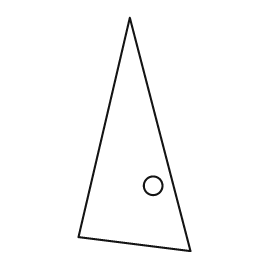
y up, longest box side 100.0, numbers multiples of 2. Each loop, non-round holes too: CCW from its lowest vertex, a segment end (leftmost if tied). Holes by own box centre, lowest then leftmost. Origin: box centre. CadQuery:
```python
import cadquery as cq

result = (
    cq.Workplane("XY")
    .moveTo(24.0, -50.0)
    .lineTo(-2.0, 50.0)
    .lineTo(-24.0, -44.0)
    .close()
    .moveTo(8.0, -22.0)
    .circle(4.0)
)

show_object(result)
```